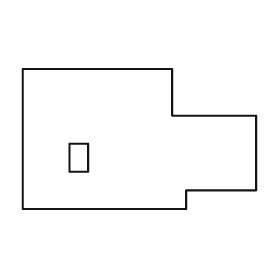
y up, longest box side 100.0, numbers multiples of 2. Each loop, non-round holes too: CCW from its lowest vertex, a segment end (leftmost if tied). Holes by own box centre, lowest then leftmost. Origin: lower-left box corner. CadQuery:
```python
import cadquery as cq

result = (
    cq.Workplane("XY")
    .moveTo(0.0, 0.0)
    .lineTo(70.0, 0.0)
    .lineTo(70.0, 8.0)
    .lineTo(100.0, 8.0)
    .lineTo(100.0, 40.0)
    .lineTo(64.0, 40.0)
    .lineTo(64.0, 60.0)
    .lineTo(0.0, 60.0)
    .close()
    .moveTo(20.0, 16.0)
    .lineTo(28.0, 16.0)
    .lineTo(28.0, 28.0)
    .lineTo(20.0, 28.0)
    .close()
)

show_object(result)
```